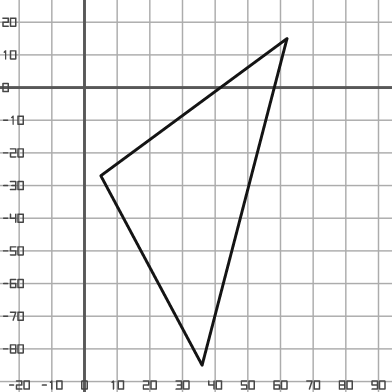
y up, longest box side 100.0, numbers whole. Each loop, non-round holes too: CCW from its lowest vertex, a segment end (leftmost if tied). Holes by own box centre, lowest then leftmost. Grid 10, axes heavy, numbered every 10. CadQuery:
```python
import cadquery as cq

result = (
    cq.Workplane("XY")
    .moveTo(36.0, -85.0)
    .lineTo(62.0, 15.0)
    .lineTo(5.0, -27.0)
    .close()
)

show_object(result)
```